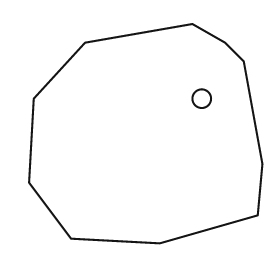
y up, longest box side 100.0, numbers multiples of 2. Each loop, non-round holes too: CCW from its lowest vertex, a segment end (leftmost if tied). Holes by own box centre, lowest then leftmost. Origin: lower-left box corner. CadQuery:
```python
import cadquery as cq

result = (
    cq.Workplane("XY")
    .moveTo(56.0, 0.0)
    .lineTo(98.0, 12.0)
    .lineTo(100.0, 34.0)
    .lineTo(92.0, 78.0)
    .lineTo(84.0, 86.0)
    .lineTo(70.0, 94.0)
    .lineTo(24.0, 86.0)
    .lineTo(2.0, 62.0)
    .lineTo(0.0, 26.0)
    .lineTo(18.0, 2.0)
    .close()
    .moveTo(74.0, 62.0)
    .circle(4.0)
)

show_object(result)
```